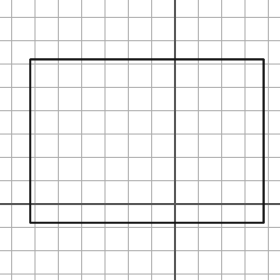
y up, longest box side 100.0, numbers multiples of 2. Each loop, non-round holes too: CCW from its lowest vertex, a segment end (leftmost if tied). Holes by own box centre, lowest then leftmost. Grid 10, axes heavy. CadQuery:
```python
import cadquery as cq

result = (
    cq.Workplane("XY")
    .moveTo(-62.0, -8.0)
    .lineTo(38.0, -8.0)
    .lineTo(38.0, 62.0)
    .lineTo(-62.0, 62.0)
    .close()
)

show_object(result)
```